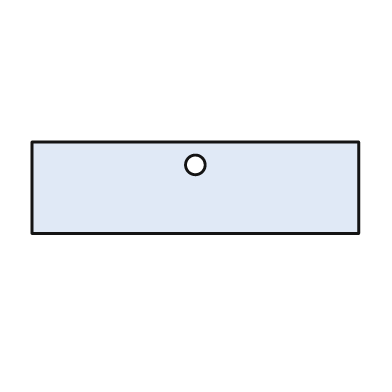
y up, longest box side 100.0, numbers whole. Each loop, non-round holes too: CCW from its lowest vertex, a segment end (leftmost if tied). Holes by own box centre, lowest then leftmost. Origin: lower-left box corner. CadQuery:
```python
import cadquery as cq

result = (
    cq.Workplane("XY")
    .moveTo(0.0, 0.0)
    .lineTo(100.0, 0.0)
    .lineTo(100.0, 28.0)
    .lineTo(0.0, 28.0)
    .close()
    .moveTo(50.0, 21.0)
    .circle(3.0)
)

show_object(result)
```